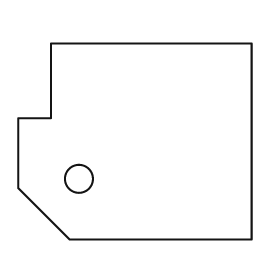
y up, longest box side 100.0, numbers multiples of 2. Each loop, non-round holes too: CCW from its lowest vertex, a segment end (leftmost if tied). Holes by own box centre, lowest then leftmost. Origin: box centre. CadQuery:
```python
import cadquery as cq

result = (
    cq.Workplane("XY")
    .moveTo(-28.0, -42.0)
    .lineTo(50.0, -42.0)
    .lineTo(50.0, 42.0)
    .lineTo(-36.0, 42.0)
    .lineTo(-36.0, 10.0)
    .lineTo(-50.0, 10.0)
    .lineTo(-50.0, -20.0)
    .close()
    .moveTo(-24.0, -16.0)
    .circle(6.0)
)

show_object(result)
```